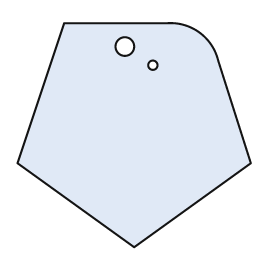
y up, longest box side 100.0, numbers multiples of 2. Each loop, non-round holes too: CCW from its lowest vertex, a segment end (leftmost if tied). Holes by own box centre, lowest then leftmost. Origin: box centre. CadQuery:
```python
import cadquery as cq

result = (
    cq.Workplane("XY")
    .moveTo(0.0, -48.0)
    .lineTo(50.0, -12.0)
    .lineTo(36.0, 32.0)
    .threePointArc((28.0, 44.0), (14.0, 48.0))
    .lineTo(-30.0, 48.0)
    .lineTo(-50.0, -12.0)
    .close()
    .moveTo(8.0, 30.0)
    .circle(2.0)
    .moveTo(-4.0, 38.0)
    .circle(4.0)
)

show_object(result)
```